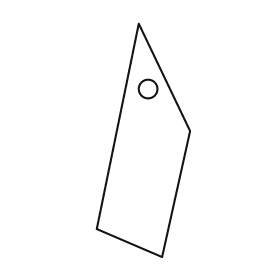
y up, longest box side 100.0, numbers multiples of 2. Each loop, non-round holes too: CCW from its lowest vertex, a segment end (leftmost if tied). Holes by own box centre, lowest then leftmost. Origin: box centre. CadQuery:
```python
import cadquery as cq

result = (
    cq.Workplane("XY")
    .moveTo(8.0, -50.0)
    .lineTo(20.0, 4.0)
    .lineTo(-2.0, 50.0)
    .lineTo(-20.0, -38.0)
    .close()
    .moveTo(2.0, 22.0)
    .circle(4.0)
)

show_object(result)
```